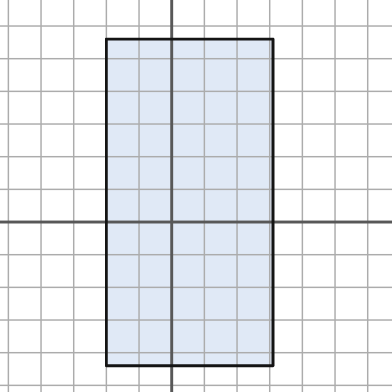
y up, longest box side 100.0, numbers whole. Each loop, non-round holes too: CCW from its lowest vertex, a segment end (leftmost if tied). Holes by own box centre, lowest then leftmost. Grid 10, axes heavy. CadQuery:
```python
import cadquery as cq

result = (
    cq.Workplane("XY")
    .moveTo(-20.0, -44.0)
    .lineTo(31.0, -44.0)
    .lineTo(31.0, 56.0)
    .lineTo(-20.0, 56.0)
    .close()
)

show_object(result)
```